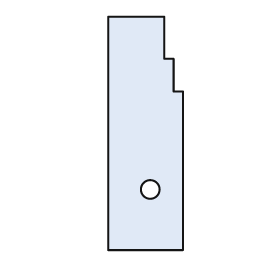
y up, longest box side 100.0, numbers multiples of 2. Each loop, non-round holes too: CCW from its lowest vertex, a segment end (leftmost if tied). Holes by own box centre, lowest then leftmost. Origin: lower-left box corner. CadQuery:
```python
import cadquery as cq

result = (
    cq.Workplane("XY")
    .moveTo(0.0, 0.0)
    .lineTo(32.0, 0.0)
    .lineTo(32.0, 68.0)
    .lineTo(28.0, 68.0)
    .lineTo(28.0, 82.0)
    .lineTo(24.0, 82.0)
    .lineTo(24.0, 100.0)
    .lineTo(0.0, 100.0)
    .close()
    .moveTo(18.0, 26.0)
    .circle(4.0)
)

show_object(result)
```